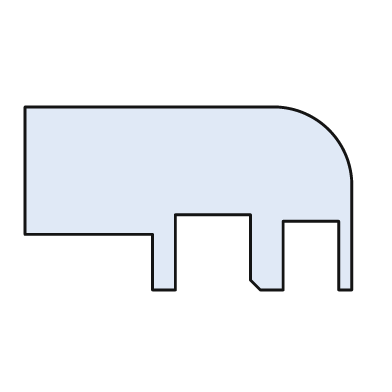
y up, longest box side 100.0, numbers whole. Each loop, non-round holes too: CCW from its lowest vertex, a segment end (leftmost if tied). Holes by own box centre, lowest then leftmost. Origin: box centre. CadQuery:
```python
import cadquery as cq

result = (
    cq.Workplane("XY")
    .moveTo(-11.0, -28.0)
    .lineTo(-4.0, -28.0)
    .lineTo(-4.0, -5.0)
    .lineTo(19.0, -5.0)
    .lineTo(19.0, -25.0)
    .lineTo(22.0, -28.0)
    .lineTo(29.0, -28.0)
    .lineTo(29.0, -7.0)
    .lineTo(46.0, -7.0)
    .lineTo(46.0, -28.0)
    .lineTo(50.0, -28.0)
    .lineTo(50.0, 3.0)
    .threePointArc((43.0, 21.0), (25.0, 28.0))
    .lineTo(-50.0, 28.0)
    .lineTo(-50.0, -11.0)
    .lineTo(-11.0, -11.0)
    .close()
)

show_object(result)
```